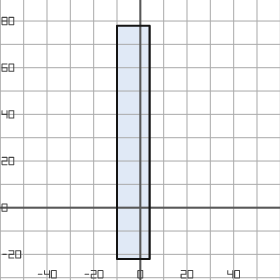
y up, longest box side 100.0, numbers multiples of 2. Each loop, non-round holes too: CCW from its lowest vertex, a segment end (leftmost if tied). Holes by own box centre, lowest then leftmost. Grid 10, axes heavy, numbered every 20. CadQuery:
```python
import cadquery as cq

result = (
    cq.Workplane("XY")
    .moveTo(-10.0, -22.0)
    .lineTo(4.0, -22.0)
    .lineTo(4.0, 78.0)
    .lineTo(-10.0, 78.0)
    .close()
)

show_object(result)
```